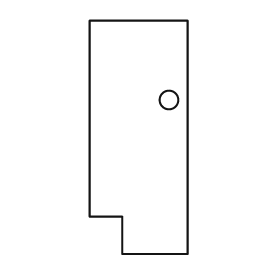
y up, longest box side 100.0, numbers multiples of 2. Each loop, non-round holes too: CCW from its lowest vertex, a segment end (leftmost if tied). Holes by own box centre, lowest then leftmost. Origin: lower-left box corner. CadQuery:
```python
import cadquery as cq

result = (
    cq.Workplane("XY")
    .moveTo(14.0, 0.0)
    .lineTo(42.0, 0.0)
    .lineTo(42.0, 100.0)
    .lineTo(0.0, 100.0)
    .lineTo(0.0, 16.0)
    .lineTo(14.0, 16.0)
    .close()
    .moveTo(34.0, 66.0)
    .circle(4.0)
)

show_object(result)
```